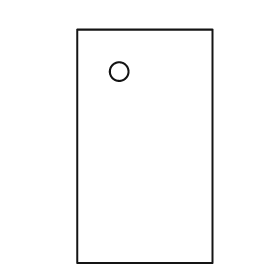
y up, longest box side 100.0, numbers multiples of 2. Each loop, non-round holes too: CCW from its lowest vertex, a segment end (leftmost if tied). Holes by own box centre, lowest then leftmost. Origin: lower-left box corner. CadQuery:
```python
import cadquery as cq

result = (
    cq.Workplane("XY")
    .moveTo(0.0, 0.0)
    .lineTo(58.0, 0.0)
    .lineTo(58.0, 100.0)
    .lineTo(0.0, 100.0)
    .close()
    .moveTo(18.0, 82.0)
    .circle(4.0)
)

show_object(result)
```